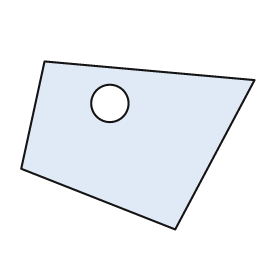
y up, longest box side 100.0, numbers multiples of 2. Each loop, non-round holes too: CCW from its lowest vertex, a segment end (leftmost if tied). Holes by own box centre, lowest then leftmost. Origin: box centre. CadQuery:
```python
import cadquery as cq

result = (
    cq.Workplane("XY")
    .moveTo(16.0, -36.0)
    .lineTo(50.0, 28.0)
    .lineTo(-40.0, 36.0)
    .lineTo(-50.0, -10.0)
    .close()
    .moveTo(-12.0, 18.0)
    .circle(8.0)
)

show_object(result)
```